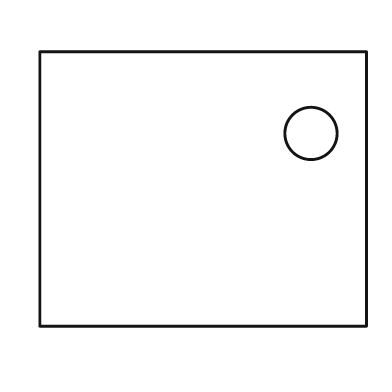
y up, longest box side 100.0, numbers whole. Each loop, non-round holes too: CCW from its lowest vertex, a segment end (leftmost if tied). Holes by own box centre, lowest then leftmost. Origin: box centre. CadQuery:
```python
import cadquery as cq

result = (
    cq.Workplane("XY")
    .moveTo(-50.0, -42.0)
    .lineTo(50.0, -42.0)
    .lineTo(50.0, 42.0)
    .lineTo(-50.0, 42.0)
    .close()
    .moveTo(33.0, 17.0)
    .circle(8.0)
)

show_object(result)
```